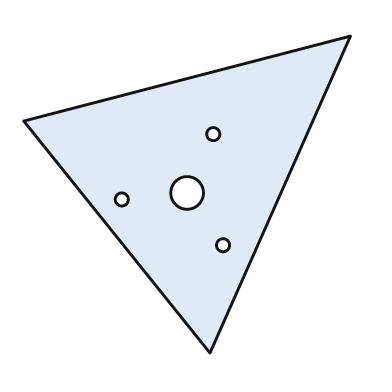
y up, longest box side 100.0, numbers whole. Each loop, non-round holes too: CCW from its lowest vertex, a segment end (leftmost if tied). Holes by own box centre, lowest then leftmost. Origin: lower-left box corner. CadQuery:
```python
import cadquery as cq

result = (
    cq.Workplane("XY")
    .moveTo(57.0, 0.0)
    .lineTo(100.0, 97.0)
    .lineTo(0.0, 71.0)
    .close()
    .moveTo(61.0, 33.0)
    .circle(2.0)
    .moveTo(30.0, 47.0)
    .circle(2.0)
    .moveTo(50.0, 49.0)
    .circle(5.0)
    .moveTo(58.0, 67.0)
    .circle(2.0)
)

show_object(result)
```